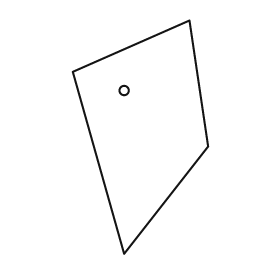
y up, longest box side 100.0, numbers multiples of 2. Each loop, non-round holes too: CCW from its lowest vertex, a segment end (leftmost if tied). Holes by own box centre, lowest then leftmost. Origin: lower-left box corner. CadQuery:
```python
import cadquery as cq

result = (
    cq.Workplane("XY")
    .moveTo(22.0, 0.0)
    .lineTo(58.0, 46.0)
    .lineTo(50.0, 100.0)
    .lineTo(0.0, 78.0)
    .close()
    .moveTo(22.0, 70.0)
    .circle(2.0)
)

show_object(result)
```